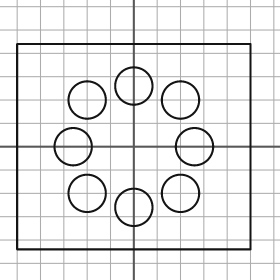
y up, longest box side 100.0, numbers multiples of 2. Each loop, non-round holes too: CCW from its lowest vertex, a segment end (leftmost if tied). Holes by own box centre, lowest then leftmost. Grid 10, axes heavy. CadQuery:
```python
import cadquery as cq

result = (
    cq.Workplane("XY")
    .moveTo(-50.0, -44.0)
    .lineTo(50.0, -44.0)
    .lineTo(50.0, 44.0)
    .lineTo(-50.0, 44.0)
    .close()
    .moveTo(0.0, -26.0)
    .circle(8.0)
    .moveTo(-20.0, -20.0)
    .circle(8.0)
    .moveTo(20.0, -20.0)
    .circle(8.0)
    .moveTo(-26.0, 0.0)
    .circle(8.0)
    .moveTo(26.0, 0.0)
    .circle(8.0)
    .moveTo(-20.0, 20.0)
    .circle(8.0)
    .moveTo(20.0, 20.0)
    .circle(8.0)
    .moveTo(0.0, 26.0)
    .circle(8.0)
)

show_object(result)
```